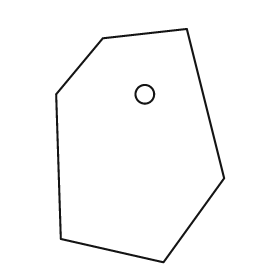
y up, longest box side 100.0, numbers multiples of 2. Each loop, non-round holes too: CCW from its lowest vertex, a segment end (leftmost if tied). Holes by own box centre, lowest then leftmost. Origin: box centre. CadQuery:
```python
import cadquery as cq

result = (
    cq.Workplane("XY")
    .moveTo(10.0, -50.0)
    .lineTo(36.0, -14.0)
    .lineTo(20.0, 50.0)
    .lineTo(-16.0, 46.0)
    .lineTo(-36.0, 22.0)
    .lineTo(-34.0, -40.0)
    .close()
    .moveTo(2.0, 22.0)
    .circle(4.0)
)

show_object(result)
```